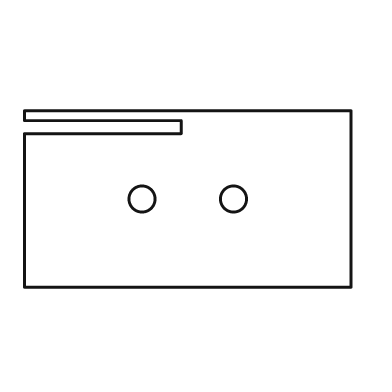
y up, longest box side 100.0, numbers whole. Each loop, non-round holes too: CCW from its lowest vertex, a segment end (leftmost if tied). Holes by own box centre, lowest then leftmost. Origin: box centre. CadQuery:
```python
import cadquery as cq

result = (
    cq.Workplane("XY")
    .moveTo(-50.0, -27.0)
    .lineTo(50.0, -27.0)
    .lineTo(50.0, 27.0)
    .lineTo(-50.0, 27.0)
    .lineTo(-50.0, 24.0)
    .lineTo(-2.0, 24.0)
    .lineTo(-2.0, 20.0)
    .lineTo(-50.0, 20.0)
    .close()
    .moveTo(-14.0, 0.0)
    .circle(4.0)
    .moveTo(14.0, 0.0)
    .circle(4.0)
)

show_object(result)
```